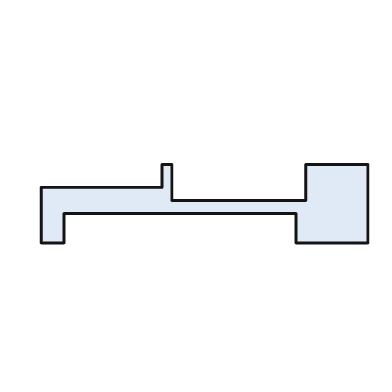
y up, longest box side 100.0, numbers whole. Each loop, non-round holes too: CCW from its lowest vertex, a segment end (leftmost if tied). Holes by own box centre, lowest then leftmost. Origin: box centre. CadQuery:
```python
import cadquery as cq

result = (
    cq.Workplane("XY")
    .moveTo(-50.0, -12.0)
    .lineTo(-43.0, -12.0)
    .lineTo(-43.0, -3.0)
    .lineTo(28.0, -3.0)
    .lineTo(28.0, -12.0)
    .lineTo(50.0, -12.0)
    .lineTo(50.0, 12.0)
    .lineTo(31.0, 12.0)
    .lineTo(31.0, 1.0)
    .lineTo(-10.0, 1.0)
    .lineTo(-10.0, 12.0)
    .lineTo(-13.0, 12.0)
    .lineTo(-13.0, 5.0)
    .lineTo(-50.0, 5.0)
    .close()
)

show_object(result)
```